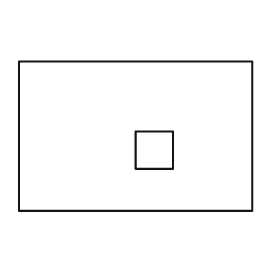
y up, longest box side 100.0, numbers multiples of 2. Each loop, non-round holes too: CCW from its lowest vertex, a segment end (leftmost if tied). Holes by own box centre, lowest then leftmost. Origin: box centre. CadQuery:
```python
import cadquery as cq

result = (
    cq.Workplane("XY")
    .moveTo(-50.0, -32.0)
    .lineTo(50.0, -32.0)
    .lineTo(50.0, 32.0)
    .lineTo(-50.0, 32.0)
    .close()
    .moveTo(0.0, -14.0)
    .lineTo(16.0, -14.0)
    .lineTo(16.0, 2.0)
    .lineTo(0.0, 2.0)
    .close()
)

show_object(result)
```